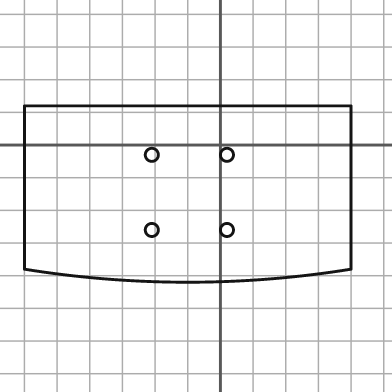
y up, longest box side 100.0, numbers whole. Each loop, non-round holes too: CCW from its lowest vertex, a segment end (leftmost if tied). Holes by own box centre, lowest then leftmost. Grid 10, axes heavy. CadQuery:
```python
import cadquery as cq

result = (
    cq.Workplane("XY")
    .moveTo(-60.0, -38.0)
    .threePointArc((-10.0, -42.0), (40.0, -38.0))
    .lineTo(40.0, 12.0)
    .lineTo(-60.0, 12.0)
    .close()
    .moveTo(-21.0, -26.0)
    .circle(2.0)
    .moveTo(2.0, -26.0)
    .circle(2.0)
    .moveTo(-21.0, -3.0)
    .circle(2.0)
    .moveTo(2.0, -3.0)
    .circle(2.0)
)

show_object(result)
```